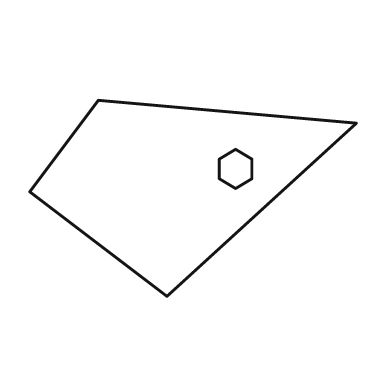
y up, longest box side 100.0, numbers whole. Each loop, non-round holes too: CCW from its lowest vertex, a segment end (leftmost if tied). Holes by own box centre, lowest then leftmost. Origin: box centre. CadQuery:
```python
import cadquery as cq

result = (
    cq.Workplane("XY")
    .moveTo(-8.0, -30.0)
    .lineTo(50.0, 23.0)
    .lineTo(-29.0, 30.0)
    .lineTo(-50.0, 2.0)
    .close()
    .moveTo(13.0, 3.0)
    .lineTo(18.0, 6.0)
    .lineTo(18.0, 12.0)
    .lineTo(13.0, 15.0)
    .lineTo(8.0, 12.0)
    .lineTo(8.0, 6.0)
    .close()
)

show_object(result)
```